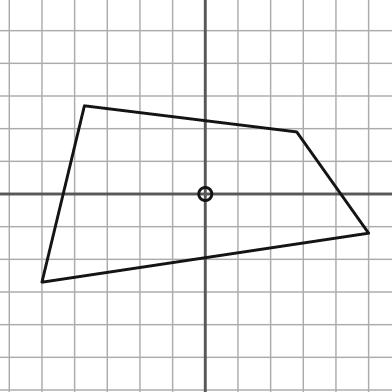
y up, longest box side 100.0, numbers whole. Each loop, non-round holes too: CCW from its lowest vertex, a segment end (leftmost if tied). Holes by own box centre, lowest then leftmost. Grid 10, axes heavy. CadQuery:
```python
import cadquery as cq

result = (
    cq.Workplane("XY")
    .moveTo(-50.0, -27.0)
    .lineTo(50.0, -12.0)
    .lineTo(28.0, 19.0)
    .lineTo(-37.0, 27.0)
    .close()
    .moveTo(0.0, 0.0)
    .circle(2.0)
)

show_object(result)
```